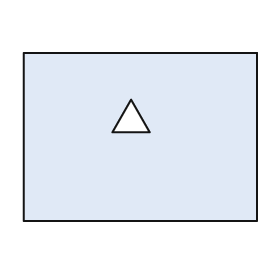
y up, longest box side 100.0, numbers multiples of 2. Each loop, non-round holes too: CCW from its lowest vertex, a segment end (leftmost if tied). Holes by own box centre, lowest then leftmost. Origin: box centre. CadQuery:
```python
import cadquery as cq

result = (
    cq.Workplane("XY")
    .moveTo(-50.0, -36.0)
    .lineTo(50.0, -36.0)
    .lineTo(50.0, 36.0)
    .lineTo(-50.0, 36.0)
    .close()
    .moveTo(-12.0, 2.0)
    .lineTo(4.0, 2.0)
    .lineTo(-4.0, 16.0)
    .close()
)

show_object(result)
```